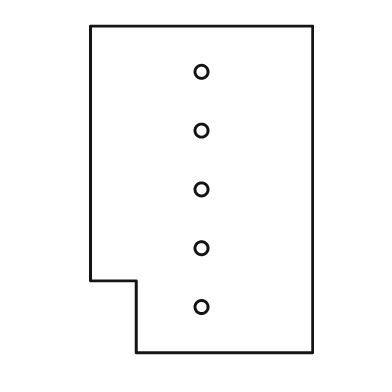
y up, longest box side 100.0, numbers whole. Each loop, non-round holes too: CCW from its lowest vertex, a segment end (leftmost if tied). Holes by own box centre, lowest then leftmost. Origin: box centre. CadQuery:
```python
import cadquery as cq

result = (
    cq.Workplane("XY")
    .moveTo(-20.0, -50.0)
    .lineTo(34.0, -50.0)
    .lineTo(34.0, 50.0)
    .lineTo(-34.0, 50.0)
    .lineTo(-34.0, -28.0)
    .lineTo(-20.0, -28.0)
    .close()
    .moveTo(0.0, -36.0)
    .circle(2.0)
    .moveTo(0.0, -18.0)
    .circle(2.0)
    .moveTo(0.0, 0.0)
    .circle(2.0)
    .moveTo(0.0, 18.0)
    .circle(2.0)
    .moveTo(0.0, 36.0)
    .circle(2.0)
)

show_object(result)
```